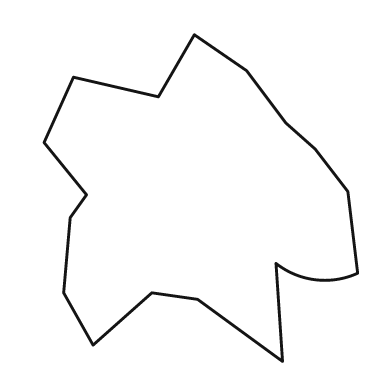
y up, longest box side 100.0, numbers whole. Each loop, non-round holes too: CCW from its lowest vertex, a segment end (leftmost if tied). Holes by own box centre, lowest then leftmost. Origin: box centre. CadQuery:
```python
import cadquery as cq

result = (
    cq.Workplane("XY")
    .moveTo(25.0, -50.0)
    .lineTo(23.0, -20.0)
    .threePointArc((35.0, -25.0), (48.0, -23.0))
    .lineTo(45.0, 2.0)
    .lineTo(35.0, 15.0)
    .lineTo(26.0, 23.0)
    .lineTo(14.0, 39.0)
    .lineTo(-2.0, 50.0)
    .lineTo(-13.0, 31.0)
    .lineTo(-39.0, 37.0)
    .lineTo(-48.0, 17.0)
    .lineTo(-35.0, 1.0)
    .lineTo(-40.0, -6.0)
    .lineTo(-42.0, -29.0)
    .lineTo(-33.0, -45.0)
    .lineTo(-15.0, -29.0)
    .lineTo(-1.0, -31.0)
    .close()
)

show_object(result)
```